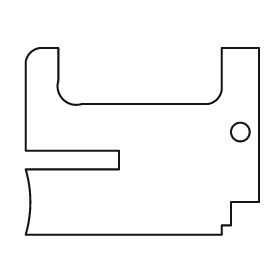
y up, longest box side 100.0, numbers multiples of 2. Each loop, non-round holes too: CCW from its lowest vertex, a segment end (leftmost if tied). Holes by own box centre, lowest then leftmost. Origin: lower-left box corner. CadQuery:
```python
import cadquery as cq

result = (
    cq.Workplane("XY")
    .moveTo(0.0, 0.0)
    .lineTo(84.0, 0.0)
    .lineTo(84.0, 4.0)
    .lineTo(88.0, 4.0)
    .lineTo(88.0, 14.0)
    .lineTo(100.0, 14.0)
    .lineTo(100.0, 80.0)
    .lineTo(84.0, 80.0)
    .lineTo(84.0, 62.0)
    .threePointArc((82.0, 58.0), (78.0, 56.0))
    .lineTo(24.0, 56.0)
    .threePointArc((16.0, 58.0), (14.0, 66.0))
    .lineTo(14.0, 80.0)
    .lineTo(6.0, 80.0)
    .threePointArc((2.0, 78.0), (0.0, 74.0))
    .lineTo(0.0, 36.0)
    .lineTo(40.0, 36.0)
    .lineTo(40.0, 28.0)
    .lineTo(0.0, 28.0)
    .threePointArc((2.0, 14.0), (0.0, 0.0))
    .close()
    .moveTo(92.0, 44.0)
    .circle(4.0)
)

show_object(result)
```